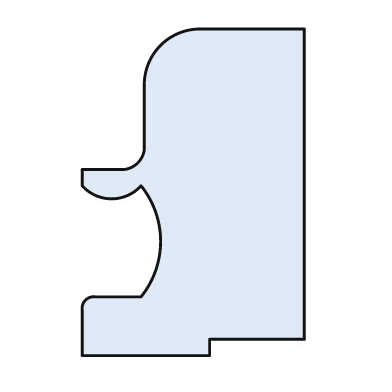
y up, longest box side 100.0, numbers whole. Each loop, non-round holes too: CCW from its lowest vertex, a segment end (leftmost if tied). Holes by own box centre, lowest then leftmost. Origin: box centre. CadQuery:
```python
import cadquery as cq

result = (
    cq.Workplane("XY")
    .moveTo(-34.0, -50.0)
    .lineTo(5.0, -50.0)
    .lineTo(5.0, -45.0)
    .lineTo(34.0, -45.0)
    .lineTo(34.0, 50.0)
    .lineTo(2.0, 50.0)
    .threePointArc((-10.0, 45.0), (-15.0, 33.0))
    .lineTo(-15.0, 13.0)
    .threePointArc((-17.0, 9.0), (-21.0, 7.0))
    .lineTo(-34.0, 7.0)
    .lineTo(-34.0, 2.0)
    .threePointArc((-25.0, -2.0), (-16.0, 2.0))
    .threePointArc((-10.0, -15.0), (-16.0, -32.0))
    .lineTo(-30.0, -32.0)
    .threePointArc((-33.0, -33.0), (-34.0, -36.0))
    .close()
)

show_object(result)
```